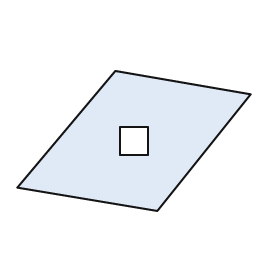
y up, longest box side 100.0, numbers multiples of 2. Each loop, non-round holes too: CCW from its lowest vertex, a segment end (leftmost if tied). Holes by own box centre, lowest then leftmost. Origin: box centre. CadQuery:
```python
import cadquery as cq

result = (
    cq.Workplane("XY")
    .moveTo(10.0, -30.0)
    .lineTo(50.0, 20.0)
    .lineTo(-8.0, 30.0)
    .lineTo(-50.0, -20.0)
    .close()
    .moveTo(-6.0, -6.0)
    .lineTo(6.0, -6.0)
    .lineTo(6.0, 6.0)
    .lineTo(-6.0, 6.0)
    .close()
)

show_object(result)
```